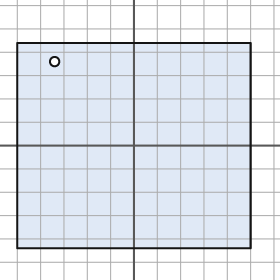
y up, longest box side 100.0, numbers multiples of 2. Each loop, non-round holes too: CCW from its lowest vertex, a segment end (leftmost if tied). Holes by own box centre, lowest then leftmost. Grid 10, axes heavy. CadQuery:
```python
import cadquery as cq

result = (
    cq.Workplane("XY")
    .moveTo(-50.0, -44.0)
    .lineTo(50.0, -44.0)
    .lineTo(50.0, 44.0)
    .lineTo(-50.0, 44.0)
    .close()
    .moveTo(-34.0, 36.0)
    .circle(2.0)
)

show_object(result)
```